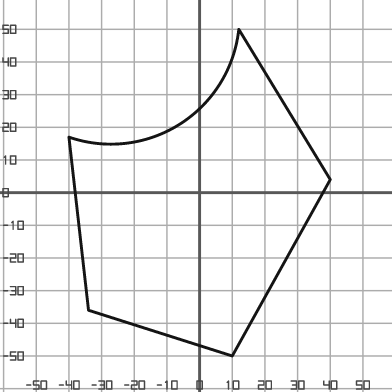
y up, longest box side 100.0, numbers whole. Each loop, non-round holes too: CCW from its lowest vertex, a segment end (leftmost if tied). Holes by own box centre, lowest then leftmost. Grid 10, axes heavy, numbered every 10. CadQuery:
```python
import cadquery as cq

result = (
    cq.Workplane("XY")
    .moveTo(10.0, -50.0)
    .lineTo(40.0, 4.0)
    .lineTo(12.0, 50.0)
    .threePointArc((-6.0, 21.0), (-40.0, 17.0))
    .lineTo(-34.0, -36.0)
    .close()
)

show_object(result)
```